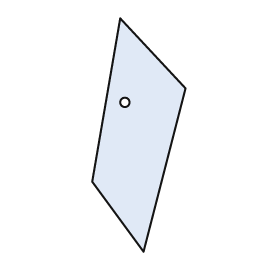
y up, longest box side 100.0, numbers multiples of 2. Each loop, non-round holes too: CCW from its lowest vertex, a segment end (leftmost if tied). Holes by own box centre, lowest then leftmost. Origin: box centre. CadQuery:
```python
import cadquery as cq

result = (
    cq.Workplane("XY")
    .moveTo(2.0, -50.0)
    .lineTo(20.0, 20.0)
    .lineTo(-8.0, 50.0)
    .lineTo(-20.0, -20.0)
    .close()
    .moveTo(-6.0, 14.0)
    .circle(2.0)
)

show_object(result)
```